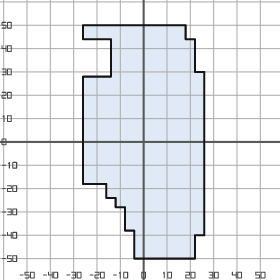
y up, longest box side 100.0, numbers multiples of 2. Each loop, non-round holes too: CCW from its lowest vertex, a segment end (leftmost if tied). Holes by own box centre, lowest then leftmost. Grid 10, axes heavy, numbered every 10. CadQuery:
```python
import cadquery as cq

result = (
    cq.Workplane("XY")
    .moveTo(-4.0, -50.0)
    .lineTo(22.0, -50.0)
    .lineTo(22.0, -40.0)
    .lineTo(26.0, -40.0)
    .lineTo(26.0, 30.0)
    .lineTo(22.0, 30.0)
    .lineTo(22.0, 44.0)
    .lineTo(18.0, 44.0)
    .lineTo(18.0, 50.0)
    .lineTo(-26.0, 50.0)
    .lineTo(-26.0, 44.0)
    .lineTo(-14.0, 44.0)
    .lineTo(-14.0, 28.0)
    .lineTo(-26.0, 28.0)
    .lineTo(-26.0, -18.0)
    .lineTo(-16.0, -18.0)
    .lineTo(-16.0, -24.0)
    .lineTo(-12.0, -24.0)
    .lineTo(-12.0, -28.0)
    .lineTo(-8.0, -28.0)
    .lineTo(-8.0, -38.0)
    .lineTo(-4.0, -38.0)
    .close()
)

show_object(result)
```